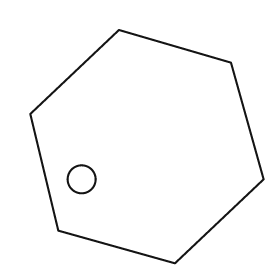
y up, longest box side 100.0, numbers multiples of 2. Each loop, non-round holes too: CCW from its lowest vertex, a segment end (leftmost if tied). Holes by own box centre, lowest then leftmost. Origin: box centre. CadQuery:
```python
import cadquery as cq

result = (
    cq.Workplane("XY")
    .moveTo(12.0, -50.0)
    .lineTo(50.0, -14.0)
    .lineTo(36.0, 36.0)
    .lineTo(-12.0, 50.0)
    .lineTo(-50.0, 14.0)
    .lineTo(-38.0, -36.0)
    .close()
    .moveTo(-28.0, -14.0)
    .circle(6.0)
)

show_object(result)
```